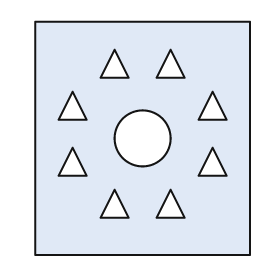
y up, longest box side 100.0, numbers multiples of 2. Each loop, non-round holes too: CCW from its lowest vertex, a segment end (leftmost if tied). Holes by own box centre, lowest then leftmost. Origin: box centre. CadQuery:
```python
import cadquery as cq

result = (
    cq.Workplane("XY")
    .moveTo(-46.0, -50.0)
    .lineTo(46.0, -50.0)
    .lineTo(46.0, 50.0)
    .lineTo(-46.0, 50.0)
    .close()
    .moveTo(-18.0, -34.0)
    .lineTo(-6.0, -34.0)
    .lineTo(-12.0, -22.0)
    .close()
    .moveTo(6.0, -34.0)
    .lineTo(18.0, -34.0)
    .lineTo(12.0, -22.0)
    .close()
    .moveTo(-36.0, -16.0)
    .lineTo(-24.0, -16.0)
    .lineTo(-30.0, -4.0)
    .close()
    .moveTo(24.0, -16.0)
    .lineTo(36.0, -16.0)
    .lineTo(30.0, -4.0)
    .close()
    .moveTo(0.0, 0.0)
    .circle(12.0)
    .moveTo(-36.0, 8.0)
    .lineTo(-24.0, 8.0)
    .lineTo(-30.0, 20.0)
    .close()
    .moveTo(24.0, 8.0)
    .lineTo(36.0, 8.0)
    .lineTo(30.0, 20.0)
    .close()
    .moveTo(-18.0, 26.0)
    .lineTo(-6.0, 26.0)
    .lineTo(-12.0, 38.0)
    .close()
    .moveTo(6.0, 26.0)
    .lineTo(18.0, 26.0)
    .lineTo(12.0, 38.0)
    .close()
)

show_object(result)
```